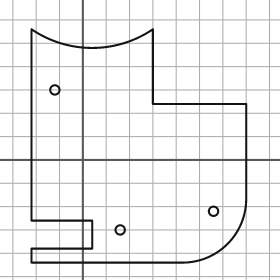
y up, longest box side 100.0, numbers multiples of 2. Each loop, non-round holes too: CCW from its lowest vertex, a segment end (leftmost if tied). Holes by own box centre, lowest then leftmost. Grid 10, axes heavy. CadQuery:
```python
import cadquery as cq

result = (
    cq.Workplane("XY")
    .moveTo(-22.0, -44.0)
    .lineTo(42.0, -44.0)
    .threePointArc((62.0, -36.0), (70.0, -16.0))
    .lineTo(70.0, 24.0)
    .lineTo(30.0, 24.0)
    .lineTo(30.0, 56.0)
    .threePointArc((4.0, 48.0), (-22.0, 56.0))
    .lineTo(-22.0, -26.0)
    .lineTo(4.0, -26.0)
    .lineTo(4.0, -38.0)
    .lineTo(-22.0, -38.0)
    .close()
    .moveTo(16.0, -30.0)
    .circle(2.0)
    .moveTo(56.0, -22.0)
    .circle(2.0)
    .moveTo(-12.0, 30.0)
    .circle(2.0)
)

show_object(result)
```